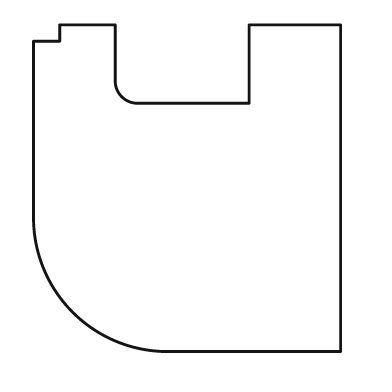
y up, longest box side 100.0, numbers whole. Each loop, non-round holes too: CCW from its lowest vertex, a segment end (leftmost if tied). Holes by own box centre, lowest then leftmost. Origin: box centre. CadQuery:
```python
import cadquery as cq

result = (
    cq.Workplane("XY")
    .moveTo(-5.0, -50.0)
    .lineTo(47.0, -50.0)
    .lineTo(47.0, 50.0)
    .lineTo(19.0, 50.0)
    .lineTo(19.0, 26.0)
    .lineTo(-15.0, 26.0)
    .threePointArc((-20.0, 28.0), (-22.0, 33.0))
    .lineTo(-22.0, 50.0)
    .lineTo(-39.0, 50.0)
    .lineTo(-39.0, 45.0)
    .lineTo(-47.0, 45.0)
    .lineTo(-47.0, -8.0)
    .threePointArc((-35.0, -38.0), (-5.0, -50.0))
    .close()
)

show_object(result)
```